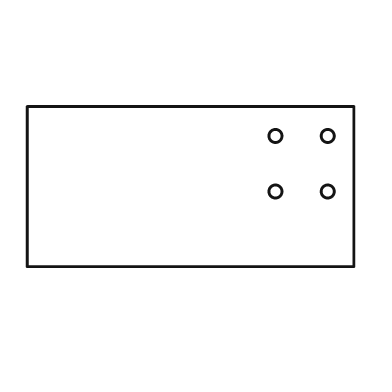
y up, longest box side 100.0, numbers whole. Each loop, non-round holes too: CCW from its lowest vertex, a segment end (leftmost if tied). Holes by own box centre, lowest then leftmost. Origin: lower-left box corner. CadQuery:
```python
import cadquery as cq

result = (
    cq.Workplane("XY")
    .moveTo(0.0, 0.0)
    .lineTo(100.0, 0.0)
    .lineTo(100.0, 49.0)
    .lineTo(0.0, 49.0)
    .close()
    .moveTo(76.0, 23.0)
    .circle(2.0)
    .moveTo(92.0, 23.0)
    .circle(2.0)
    .moveTo(76.0, 40.0)
    .circle(2.0)
    .moveTo(92.0, 40.0)
    .circle(2.0)
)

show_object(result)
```